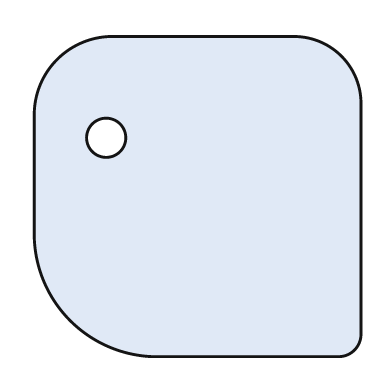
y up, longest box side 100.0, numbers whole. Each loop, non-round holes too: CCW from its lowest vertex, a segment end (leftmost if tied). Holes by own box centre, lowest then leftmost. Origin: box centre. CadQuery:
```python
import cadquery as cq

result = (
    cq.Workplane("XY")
    .moveTo(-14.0, -49.0)
    .lineTo(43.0, -49.0)
    .threePointArc((48.0, -47.0), (50.0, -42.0))
    .lineTo(50.0, 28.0)
    .threePointArc((44.0, 43.0), (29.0, 49.0))
    .lineTo(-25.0, 49.0)
    .threePointArc((-43.0, 42.0), (-50.0, 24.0))
    .lineTo(-50.0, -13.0)
    .threePointArc((-39.0, -38.0), (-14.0, -49.0))
    .close()
    .moveTo(-28.0, 18.0)
    .circle(6.0)
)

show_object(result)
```